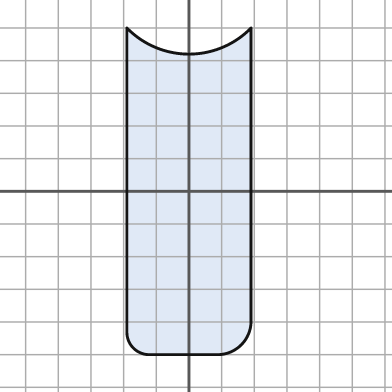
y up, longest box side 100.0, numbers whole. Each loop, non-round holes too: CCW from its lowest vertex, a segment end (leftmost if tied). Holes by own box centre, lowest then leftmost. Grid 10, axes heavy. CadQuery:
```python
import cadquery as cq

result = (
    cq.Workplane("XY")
    .moveTo(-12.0, -50.0)
    .lineTo(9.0, -50.0)
    .threePointArc((16.0, -47.0), (19.0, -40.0))
    .lineTo(19.0, 50.0)
    .threePointArc((0.0, 42.0), (-19.0, 50.0))
    .lineTo(-19.0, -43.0)
    .threePointArc((-17.0, -48.0), (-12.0, -50.0))
    .close()
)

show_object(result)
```